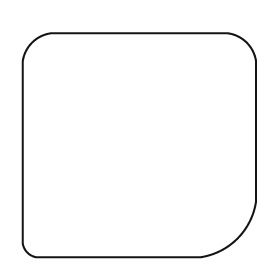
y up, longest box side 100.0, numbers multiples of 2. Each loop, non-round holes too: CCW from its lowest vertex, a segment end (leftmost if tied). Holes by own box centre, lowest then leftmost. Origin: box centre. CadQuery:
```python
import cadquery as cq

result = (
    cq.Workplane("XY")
    .moveTo(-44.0, -48.0)
    .lineTo(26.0, -48.0)
    .threePointArc((42.0, -40.0), (50.0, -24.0))
    .lineTo(50.0, 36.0)
    .threePointArc((46.0, 44.0), (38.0, 48.0))
    .lineTo(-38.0, 48.0)
    .threePointArc((-46.0, 44.0), (-50.0, 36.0))
    .lineTo(-50.0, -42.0)
    .threePointArc((-48.0, -46.0), (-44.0, -48.0))
    .close()
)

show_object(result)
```